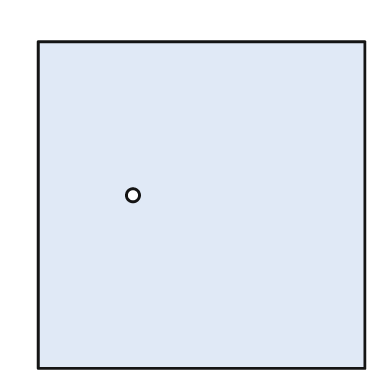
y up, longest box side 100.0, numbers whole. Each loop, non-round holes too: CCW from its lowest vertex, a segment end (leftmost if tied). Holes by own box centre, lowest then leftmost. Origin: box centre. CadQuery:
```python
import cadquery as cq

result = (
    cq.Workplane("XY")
    .moveTo(-50.0, -50.0)
    .lineTo(50.0, -50.0)
    .lineTo(50.0, 50.0)
    .lineTo(-50.0, 50.0)
    .close()
    .moveTo(-21.0, 3.0)
    .circle(2.0)
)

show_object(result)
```